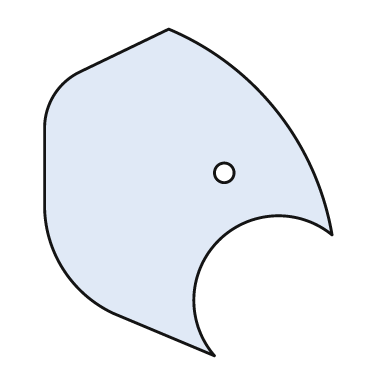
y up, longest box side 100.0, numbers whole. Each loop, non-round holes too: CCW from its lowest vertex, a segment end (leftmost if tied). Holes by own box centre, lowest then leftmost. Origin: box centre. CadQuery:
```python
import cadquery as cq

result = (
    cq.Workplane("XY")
    .moveTo(8.0, -50.0)
    .threePointArc((9.0, -15.0), (44.0, -13.0))
    .threePointArc((27.0, 25.0), (-6.0, 50.0))
    .lineTo(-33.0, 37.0)
    .threePointArc((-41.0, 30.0), (-44.0, 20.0))
    .lineTo(-44.0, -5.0)
    .threePointArc((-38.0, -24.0), (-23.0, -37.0))
    .close()
    .moveTo(11.0, 6.0)
    .circle(3.0)
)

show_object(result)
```